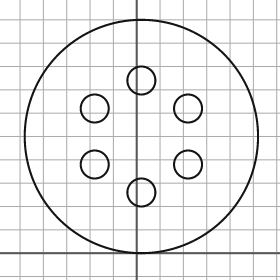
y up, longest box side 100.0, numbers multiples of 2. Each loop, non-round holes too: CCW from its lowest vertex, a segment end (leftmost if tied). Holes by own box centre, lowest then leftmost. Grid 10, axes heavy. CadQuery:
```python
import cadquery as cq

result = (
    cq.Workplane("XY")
    .moveTo(2.0, 50.0)
    .circle(50.0)
    .moveTo(2.0, 26.0)
    .circle(6.0)
    .moveTo(-18.0, 38.0)
    .circle(6.0)
    .moveTo(22.0, 38.0)
    .circle(6.0)
    .moveTo(-18.0, 62.0)
    .circle(6.0)
    .moveTo(22.0, 62.0)
    .circle(6.0)
    .moveTo(2.0, 74.0)
    .circle(6.0)
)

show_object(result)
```